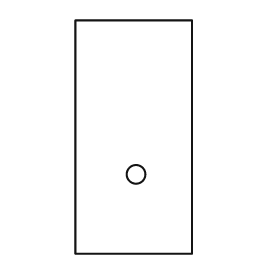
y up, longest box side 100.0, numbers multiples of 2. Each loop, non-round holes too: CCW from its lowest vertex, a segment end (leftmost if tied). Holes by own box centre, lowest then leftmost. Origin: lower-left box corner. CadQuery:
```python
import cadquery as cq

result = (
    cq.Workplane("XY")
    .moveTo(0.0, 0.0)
    .lineTo(50.0, 0.0)
    .lineTo(50.0, 100.0)
    .lineTo(0.0, 100.0)
    .close()
    .moveTo(26.0, 34.0)
    .circle(4.0)
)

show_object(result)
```